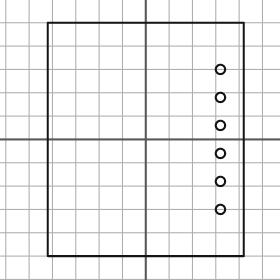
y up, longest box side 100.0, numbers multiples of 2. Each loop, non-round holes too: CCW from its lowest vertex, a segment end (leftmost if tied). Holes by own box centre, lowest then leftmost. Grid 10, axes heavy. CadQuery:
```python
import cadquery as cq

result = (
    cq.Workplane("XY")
    .moveTo(-42.0, -50.0)
    .lineTo(42.0, -50.0)
    .lineTo(42.0, 50.0)
    .lineTo(-42.0, 50.0)
    .close()
    .moveTo(32.0, -30.0)
    .circle(2.0)
    .moveTo(32.0, -18.0)
    .circle(2.0)
    .moveTo(32.0, -6.0)
    .circle(2.0)
    .moveTo(32.0, 6.0)
    .circle(2.0)
    .moveTo(32.0, 18.0)
    .circle(2.0)
    .moveTo(32.0, 30.0)
    .circle(2.0)
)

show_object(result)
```